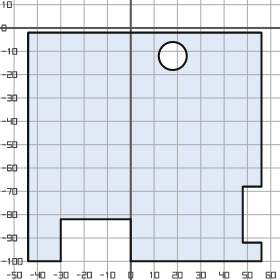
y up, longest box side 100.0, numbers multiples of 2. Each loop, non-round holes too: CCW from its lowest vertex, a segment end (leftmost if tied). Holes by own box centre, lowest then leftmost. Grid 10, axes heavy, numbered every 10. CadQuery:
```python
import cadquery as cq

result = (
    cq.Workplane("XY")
    .moveTo(-44.0, -100.0)
    .lineTo(-30.0, -100.0)
    .lineTo(-30.0, -82.0)
    .lineTo(0.0, -82.0)
    .lineTo(0.0, -100.0)
    .lineTo(56.0, -100.0)
    .lineTo(56.0, -92.0)
    .lineTo(48.0, -92.0)
    .lineTo(48.0, -68.0)
    .lineTo(56.0, -68.0)
    .lineTo(56.0, -2.0)
    .lineTo(-44.0, -2.0)
    .close()
    .moveTo(18.0, -12.0)
    .circle(6.0)
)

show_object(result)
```